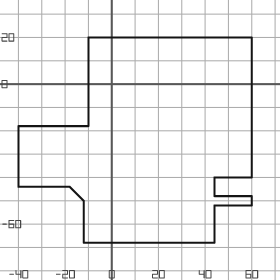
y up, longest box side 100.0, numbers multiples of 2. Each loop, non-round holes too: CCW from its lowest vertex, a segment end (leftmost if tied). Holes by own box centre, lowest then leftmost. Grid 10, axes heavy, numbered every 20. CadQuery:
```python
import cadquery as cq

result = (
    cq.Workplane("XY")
    .moveTo(-12.0, -68.0)
    .lineTo(44.0, -68.0)
    .lineTo(44.0, -52.0)
    .lineTo(60.0, -52.0)
    .lineTo(60.0, -48.0)
    .lineTo(44.0, -48.0)
    .lineTo(44.0, -40.0)
    .lineTo(60.0, -40.0)
    .lineTo(60.0, 20.0)
    .lineTo(-10.0, 20.0)
    .lineTo(-10.0, -18.0)
    .lineTo(-40.0, -18.0)
    .lineTo(-40.0, -44.0)
    .lineTo(-18.0, -44.0)
    .lineTo(-12.0, -50.0)
    .close()
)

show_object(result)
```